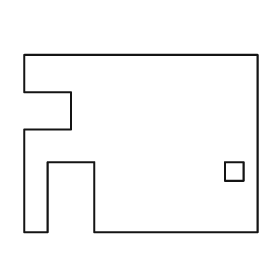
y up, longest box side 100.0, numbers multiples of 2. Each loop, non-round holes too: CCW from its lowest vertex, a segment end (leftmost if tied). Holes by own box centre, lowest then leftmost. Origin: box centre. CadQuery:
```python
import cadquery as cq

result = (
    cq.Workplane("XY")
    .moveTo(-50.0, -38.0)
    .lineTo(-40.0, -38.0)
    .lineTo(-40.0, -8.0)
    .lineTo(-20.0, -8.0)
    .lineTo(-20.0, -38.0)
    .lineTo(50.0, -38.0)
    .lineTo(50.0, 38.0)
    .lineTo(-50.0, 38.0)
    .lineTo(-50.0, 22.0)
    .lineTo(-30.0, 22.0)
    .lineTo(-30.0, 6.0)
    .lineTo(-50.0, 6.0)
    .close()
    .moveTo(36.0, -16.0)
    .lineTo(44.0, -16.0)
    .lineTo(44.0, -8.0)
    .lineTo(36.0, -8.0)
    .close()
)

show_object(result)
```